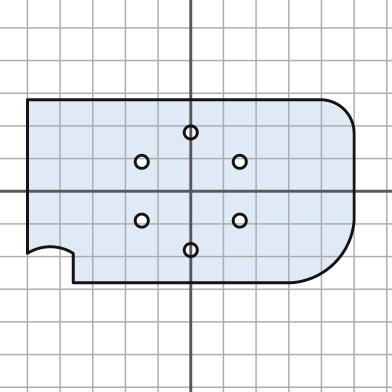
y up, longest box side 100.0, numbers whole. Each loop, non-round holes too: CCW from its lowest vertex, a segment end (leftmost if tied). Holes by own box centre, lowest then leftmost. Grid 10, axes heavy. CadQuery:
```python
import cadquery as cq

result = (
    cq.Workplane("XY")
    .moveTo(-36.0, -28.0)
    .lineTo(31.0, -28.0)
    .threePointArc((44.0, -22.0), (50.0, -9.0))
    .lineTo(50.0, 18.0)
    .threePointArc((47.0, 25.0), (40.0, 28.0))
    .lineTo(-50.0, 28.0)
    .lineTo(-50.0, -19.0)
    .threePointArc((-43.0, -17.0), (-36.0, -19.0))
    .close()
    .moveTo(0.0, -18.0)
    .circle(2.0)
    .moveTo(-15.0, -9.0)
    .circle(2.0)
    .moveTo(15.0, -9.0)
    .circle(2.0)
    .moveTo(-15.0, 9.0)
    .circle(2.0)
    .moveTo(15.0, 9.0)
    .circle(2.0)
    .moveTo(0.0, 18.0)
    .circle(2.0)
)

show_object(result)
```